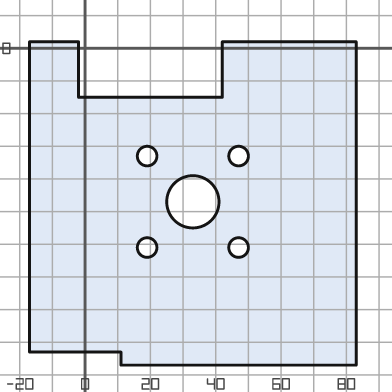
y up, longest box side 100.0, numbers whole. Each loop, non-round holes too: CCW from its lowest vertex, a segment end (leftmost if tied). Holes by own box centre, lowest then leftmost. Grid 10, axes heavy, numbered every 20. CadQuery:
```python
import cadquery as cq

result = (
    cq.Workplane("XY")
    .moveTo(11.0, -97.0)
    .lineTo(83.0, -97.0)
    .lineTo(83.0, 2.0)
    .lineTo(42.0, 2.0)
    .lineTo(42.0, -15.0)
    .lineTo(-2.0, -15.0)
    .lineTo(-2.0, 2.0)
    .lineTo(-17.0, 2.0)
    .lineTo(-17.0, -93.0)
    .lineTo(11.0, -93.0)
    .close()
    .moveTo(19.0, -61.0)
    .circle(3.0)
    .moveTo(47.0, -61.0)
    .circle(3.0)
    .moveTo(33.0, -47.0)
    .circle(8.0)
    .moveTo(19.0, -33.0)
    .circle(3.0)
    .moveTo(47.0, -33.0)
    .circle(3.0)
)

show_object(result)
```